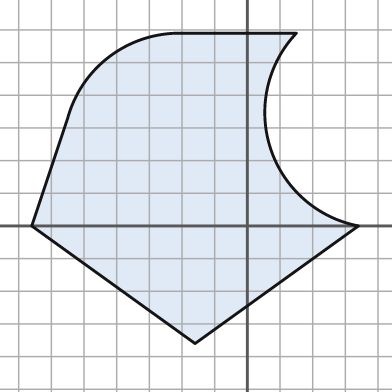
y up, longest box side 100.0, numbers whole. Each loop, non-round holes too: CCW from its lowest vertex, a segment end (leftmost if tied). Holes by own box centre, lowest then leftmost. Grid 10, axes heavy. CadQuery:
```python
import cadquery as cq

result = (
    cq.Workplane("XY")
    .moveTo(-16.0, -36.0)
    .lineTo(34.0, 0.0)
    .threePointArc((7.0, 24.0), (15.0, 59.0))
    .lineTo(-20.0, 59.0)
    .threePointArc((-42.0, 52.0), (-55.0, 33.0))
    .lineTo(-66.0, 0.0)
    .close()
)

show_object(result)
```